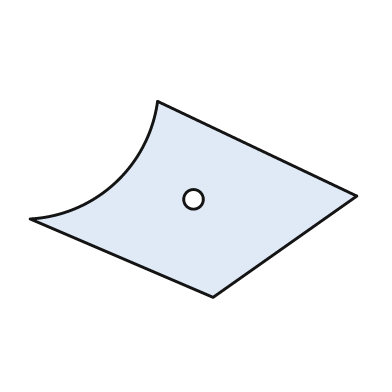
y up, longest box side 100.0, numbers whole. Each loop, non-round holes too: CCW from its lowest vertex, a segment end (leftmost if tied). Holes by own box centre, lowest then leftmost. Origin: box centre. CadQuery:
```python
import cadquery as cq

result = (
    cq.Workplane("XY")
    .moveTo(6.0, -30.0)
    .lineTo(50.0, 1.0)
    .lineTo(-11.0, 30.0)
    .threePointArc((-24.0, 5.0), (-50.0, -6.0))
    .close()
    .moveTo(0.0, 0.0)
    .circle(3.0)
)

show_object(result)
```